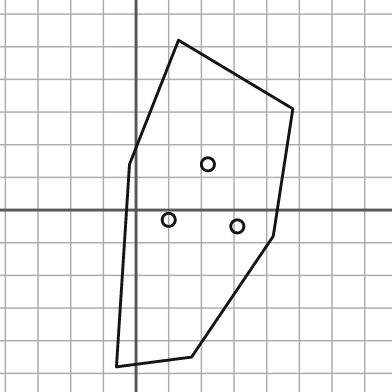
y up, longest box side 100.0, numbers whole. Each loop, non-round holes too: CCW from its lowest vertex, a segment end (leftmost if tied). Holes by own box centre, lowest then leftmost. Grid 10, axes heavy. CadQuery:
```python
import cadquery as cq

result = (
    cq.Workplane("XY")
    .moveTo(-6.0, -48.0)
    .lineTo(17.0, -45.0)
    .lineTo(42.0, -8.0)
    .lineTo(48.0, 31.0)
    .lineTo(13.0, 52.0)
    .lineTo(-2.0, 14.0)
    .close()
    .moveTo(31.0, -5.0)
    .circle(2.0)
    .moveTo(10.0, -3.0)
    .circle(2.0)
    .moveTo(22.0, 14.0)
    .circle(2.0)
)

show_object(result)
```